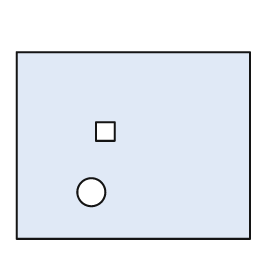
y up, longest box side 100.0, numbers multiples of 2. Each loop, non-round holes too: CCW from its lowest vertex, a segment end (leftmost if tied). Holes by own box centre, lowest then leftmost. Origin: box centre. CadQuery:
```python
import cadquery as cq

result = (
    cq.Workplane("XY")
    .moveTo(-50.0, -40.0)
    .lineTo(50.0, -40.0)
    .lineTo(50.0, 40.0)
    .lineTo(-50.0, 40.0)
    .close()
    .moveTo(-18.0, -20.0)
    .circle(6.0)
    .moveTo(-16.0, 2.0)
    .lineTo(-8.0, 2.0)
    .lineTo(-8.0, 10.0)
    .lineTo(-16.0, 10.0)
    .close()
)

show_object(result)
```